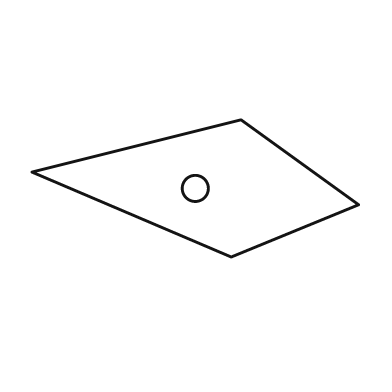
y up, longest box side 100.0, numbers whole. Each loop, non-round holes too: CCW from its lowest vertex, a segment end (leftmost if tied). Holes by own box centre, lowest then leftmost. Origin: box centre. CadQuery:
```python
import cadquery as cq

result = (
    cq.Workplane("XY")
    .moveTo(11.0, -21.0)
    .lineTo(50.0, -5.0)
    .lineTo(14.0, 21.0)
    .lineTo(-50.0, 5.0)
    .close()
    .moveTo(0.0, 0.0)
    .circle(4.0)
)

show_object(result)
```